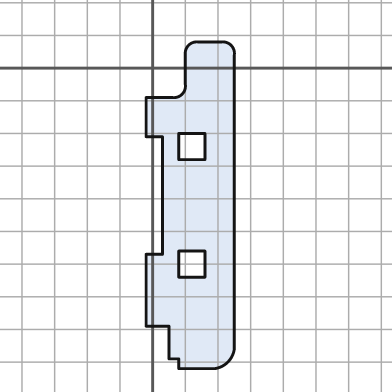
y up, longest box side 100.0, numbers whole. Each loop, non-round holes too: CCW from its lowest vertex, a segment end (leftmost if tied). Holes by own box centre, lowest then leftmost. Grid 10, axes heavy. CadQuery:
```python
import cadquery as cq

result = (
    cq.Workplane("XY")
    .moveTo(8.0, -92.0)
    .lineTo(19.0, -92.0)
    .threePointArc((23.0, -90.0), (25.0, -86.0))
    .lineTo(25.0, 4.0)
    .threePointArc((24.0, 7.0), (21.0, 8.0))
    .lineTo(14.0, 8.0)
    .threePointArc((11.0, 7.0), (10.0, 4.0))
    .lineTo(10.0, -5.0)
    .threePointArc((9.0, -8.0), (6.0, -9.0))
    .lineTo(-2.0, -9.0)
    .lineTo(-2.0, -21.0)
    .lineTo(3.0, -21.0)
    .lineTo(3.0, -57.0)
    .lineTo(-2.0, -57.0)
    .lineTo(-2.0, -79.0)
    .lineTo(5.0, -79.0)
    .lineTo(5.0, -89.0)
    .lineTo(8.0, -89.0)
    .close()
    .moveTo(8.0, -64.0)
    .lineTo(16.0, -64.0)
    .lineTo(16.0, -56.0)
    .lineTo(8.0, -56.0)
    .close()
    .moveTo(8.0, -28.0)
    .lineTo(16.0, -28.0)
    .lineTo(16.0, -20.0)
    .lineTo(8.0, -20.0)
    .close()
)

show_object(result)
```